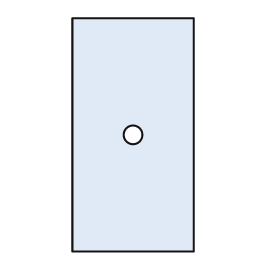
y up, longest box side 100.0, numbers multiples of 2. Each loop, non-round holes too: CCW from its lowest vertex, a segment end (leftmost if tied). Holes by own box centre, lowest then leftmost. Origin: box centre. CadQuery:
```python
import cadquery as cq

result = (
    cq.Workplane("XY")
    .moveTo(-26.0, -50.0)
    .lineTo(26.0, -50.0)
    .lineTo(26.0, 50.0)
    .lineTo(-26.0, 50.0)
    .close()
    .moveTo(0.0, 0.0)
    .circle(4.0)
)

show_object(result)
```